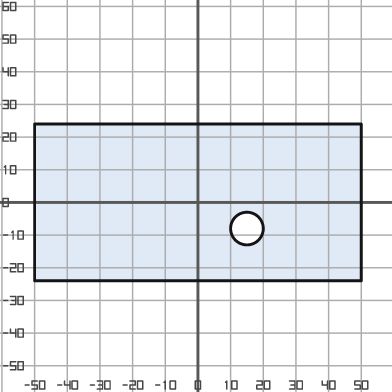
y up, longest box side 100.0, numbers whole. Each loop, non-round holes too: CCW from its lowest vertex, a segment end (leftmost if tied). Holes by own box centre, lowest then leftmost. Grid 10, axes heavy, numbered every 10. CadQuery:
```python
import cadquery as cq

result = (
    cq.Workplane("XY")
    .moveTo(-50.0, -24.0)
    .lineTo(50.0, -24.0)
    .lineTo(50.0, 24.0)
    .lineTo(-50.0, 24.0)
    .close()
    .moveTo(15.0, -8.0)
    .circle(5.0)
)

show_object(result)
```